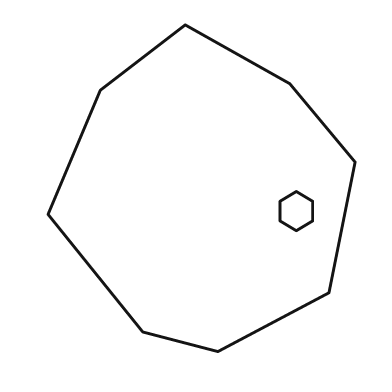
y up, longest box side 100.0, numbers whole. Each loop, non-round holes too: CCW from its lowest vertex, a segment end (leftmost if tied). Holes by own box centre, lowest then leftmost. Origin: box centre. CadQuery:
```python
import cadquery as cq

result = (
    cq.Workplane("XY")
    .moveTo(5.0, -50.0)
    .lineTo(39.0, -32.0)
    .lineTo(47.0, 8.0)
    .lineTo(27.0, 32.0)
    .lineTo(-5.0, 50.0)
    .lineTo(-31.0, 30.0)
    .lineTo(-47.0, -8.0)
    .lineTo(-18.0, -44.0)
    .close()
    .moveTo(29.0, -13.0)
    .lineTo(34.0, -10.0)
    .lineTo(34.0, -4.0)
    .lineTo(29.0, -1.0)
    .lineTo(24.0, -4.0)
    .lineTo(24.0, -10.0)
    .close()
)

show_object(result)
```